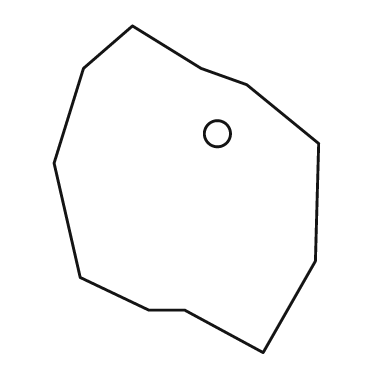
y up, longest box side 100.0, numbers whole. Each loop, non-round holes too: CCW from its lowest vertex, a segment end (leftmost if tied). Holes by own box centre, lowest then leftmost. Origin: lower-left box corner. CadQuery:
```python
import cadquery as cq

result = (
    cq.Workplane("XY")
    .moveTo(64.0, 0.0)
    .lineTo(80.0, 28.0)
    .lineTo(81.0, 64.0)
    .lineTo(59.0, 82.0)
    .lineTo(45.0, 87.0)
    .lineTo(24.0, 100.0)
    .lineTo(9.0, 87.0)
    .lineTo(0.0, 58.0)
    .lineTo(8.0, 23.0)
    .lineTo(29.0, 13.0)
    .lineTo(40.0, 13.0)
    .close()
    .moveTo(50.0, 67.0)
    .circle(4.0)
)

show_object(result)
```